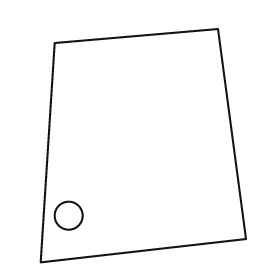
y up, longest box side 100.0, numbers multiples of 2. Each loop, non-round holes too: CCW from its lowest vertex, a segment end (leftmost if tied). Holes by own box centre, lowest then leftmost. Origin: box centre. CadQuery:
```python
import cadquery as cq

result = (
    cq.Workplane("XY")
    .moveTo(-44.0, -50.0)
    .lineTo(44.0, -40.0)
    .lineTo(32.0, 50.0)
    .lineTo(-38.0, 44.0)
    .close()
    .moveTo(-32.0, -30.0)
    .circle(6.0)
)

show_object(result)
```